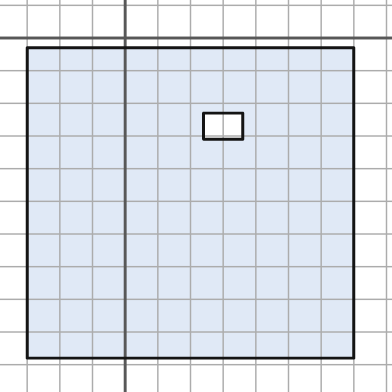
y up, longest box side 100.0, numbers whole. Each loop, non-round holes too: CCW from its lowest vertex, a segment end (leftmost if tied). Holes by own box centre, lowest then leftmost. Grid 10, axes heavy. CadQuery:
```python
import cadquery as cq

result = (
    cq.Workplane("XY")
    .moveTo(-30.0, -98.0)
    .lineTo(70.0, -98.0)
    .lineTo(70.0, -3.0)
    .lineTo(-30.0, -3.0)
    .close()
    .moveTo(24.0, -31.0)
    .lineTo(36.0, -31.0)
    .lineTo(36.0, -23.0)
    .lineTo(24.0, -23.0)
    .close()
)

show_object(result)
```